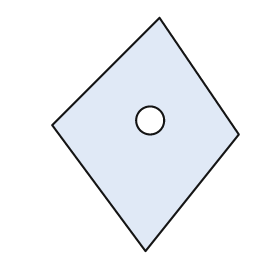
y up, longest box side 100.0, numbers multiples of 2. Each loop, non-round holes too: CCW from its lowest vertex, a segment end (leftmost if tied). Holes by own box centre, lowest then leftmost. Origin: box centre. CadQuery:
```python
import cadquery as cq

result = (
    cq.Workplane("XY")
    .moveTo(0.0, -50.0)
    .lineTo(40.0, 0.0)
    .lineTo(6.0, 50.0)
    .lineTo(-40.0, 4.0)
    .close()
    .moveTo(2.0, 6.0)
    .circle(6.0)
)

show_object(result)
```